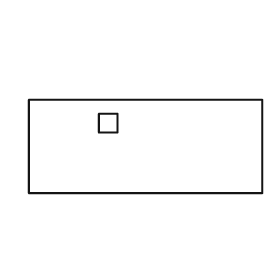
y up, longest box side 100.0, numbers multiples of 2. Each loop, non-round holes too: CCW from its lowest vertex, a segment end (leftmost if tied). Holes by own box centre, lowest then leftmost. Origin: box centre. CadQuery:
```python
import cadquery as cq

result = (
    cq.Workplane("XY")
    .moveTo(-50.0, -20.0)
    .lineTo(50.0, -20.0)
    .lineTo(50.0, 20.0)
    .lineTo(-50.0, 20.0)
    .close()
    .moveTo(-20.0, 6.0)
    .lineTo(-12.0, 6.0)
    .lineTo(-12.0, 14.0)
    .lineTo(-20.0, 14.0)
    .close()
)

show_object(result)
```